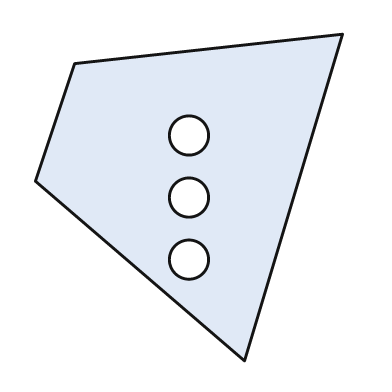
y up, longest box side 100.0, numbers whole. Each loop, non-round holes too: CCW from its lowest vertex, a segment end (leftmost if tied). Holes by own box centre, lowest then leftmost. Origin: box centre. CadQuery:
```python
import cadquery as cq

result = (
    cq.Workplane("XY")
    .moveTo(17.0, -50.0)
    .lineTo(47.0, 50.0)
    .lineTo(-35.0, 41.0)
    .lineTo(-47.0, 5.0)
    .close()
    .moveTo(0.0, -19.0)
    .circle(6.0)
    .moveTo(0.0, 0.0)
    .circle(6.0)
    .moveTo(0.0, 19.0)
    .circle(6.0)
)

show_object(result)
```